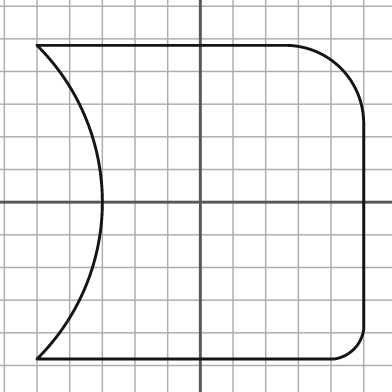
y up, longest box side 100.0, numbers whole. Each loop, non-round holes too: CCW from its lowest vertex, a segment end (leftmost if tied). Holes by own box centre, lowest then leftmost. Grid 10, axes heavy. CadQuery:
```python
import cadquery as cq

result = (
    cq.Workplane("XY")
    .moveTo(-50.0, -48.0)
    .lineTo(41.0, -48.0)
    .threePointArc((47.0, -45.0), (50.0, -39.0))
    .lineTo(50.0, 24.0)
    .threePointArc((43.0, 41.0), (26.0, 48.0))
    .lineTo(-50.0, 48.0)
    .threePointArc((-30.0, 0.0), (-50.0, -48.0))
    .close()
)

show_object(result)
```